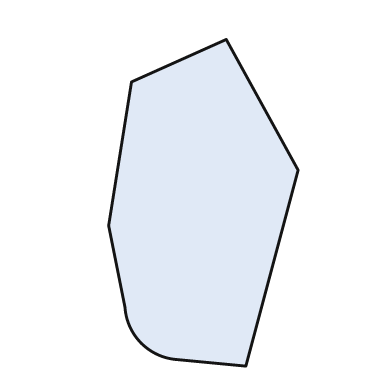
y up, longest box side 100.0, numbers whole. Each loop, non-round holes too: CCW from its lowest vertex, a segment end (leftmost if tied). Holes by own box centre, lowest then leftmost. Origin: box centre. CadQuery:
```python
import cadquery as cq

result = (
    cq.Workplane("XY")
    .moveTo(13.0, -50.0)
    .lineTo(29.0, 10.0)
    .lineTo(7.0, 50.0)
    .lineTo(-22.0, 37.0)
    .lineTo(-29.0, -7.0)
    .lineTo(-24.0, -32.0)
    .threePointArc((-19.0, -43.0), (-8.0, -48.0))
    .close()
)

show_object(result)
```